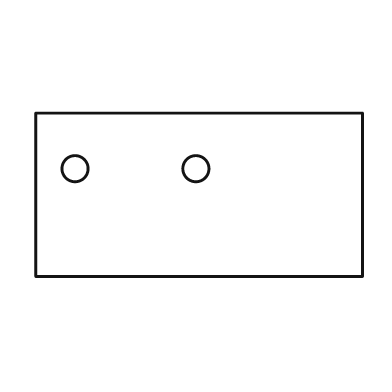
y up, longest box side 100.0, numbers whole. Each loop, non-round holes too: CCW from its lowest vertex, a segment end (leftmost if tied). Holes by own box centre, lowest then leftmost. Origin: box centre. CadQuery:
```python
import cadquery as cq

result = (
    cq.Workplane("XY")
    .moveTo(-50.0, -25.0)
    .lineTo(50.0, -25.0)
    .lineTo(50.0, 25.0)
    .lineTo(-50.0, 25.0)
    .close()
    .moveTo(-38.0, 8.0)
    .circle(4.0)
    .moveTo(-1.0, 8.0)
    .circle(4.0)
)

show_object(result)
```